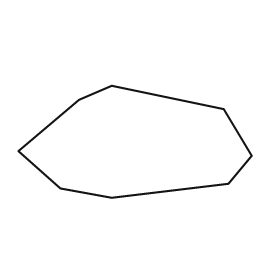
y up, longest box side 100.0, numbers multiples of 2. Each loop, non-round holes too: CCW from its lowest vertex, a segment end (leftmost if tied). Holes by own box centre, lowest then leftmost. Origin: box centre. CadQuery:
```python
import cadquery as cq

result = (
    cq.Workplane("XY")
    .moveTo(-10.0, -24.0)
    .lineTo(40.0, -18.0)
    .lineTo(50.0, -6.0)
    .lineTo(38.0, 14.0)
    .lineTo(-10.0, 24.0)
    .lineTo(-24.0, 18.0)
    .lineTo(-50.0, -4.0)
    .lineTo(-32.0, -20.0)
    .close()
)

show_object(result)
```